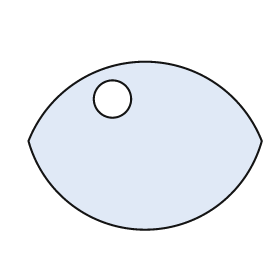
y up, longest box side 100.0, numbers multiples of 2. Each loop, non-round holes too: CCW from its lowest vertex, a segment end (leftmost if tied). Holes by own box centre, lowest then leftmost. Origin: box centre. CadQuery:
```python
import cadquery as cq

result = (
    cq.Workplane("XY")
    .moveTo(-50.0, 2.0)
    .threePointArc((0.0, -36.0), (50.0, 2.0))
    .threePointArc((0.0, 36.0), (-50.0, 2.0))
    .close()
    .moveTo(-14.0, 20.0)
    .circle(8.0)
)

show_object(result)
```